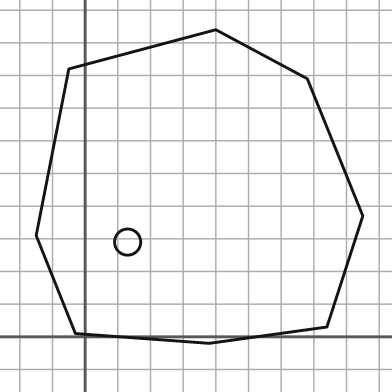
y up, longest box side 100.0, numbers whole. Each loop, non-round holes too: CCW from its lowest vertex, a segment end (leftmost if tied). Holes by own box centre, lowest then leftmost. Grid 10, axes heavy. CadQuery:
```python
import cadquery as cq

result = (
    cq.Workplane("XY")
    .moveTo(38.0, -2.0)
    .lineTo(74.0, 3.0)
    .lineTo(85.0, 37.0)
    .lineTo(68.0, 79.0)
    .lineTo(40.0, 94.0)
    .lineTo(-5.0, 82.0)
    .lineTo(-15.0, 31.0)
    .lineTo(-3.0, 1.0)
    .close()
    .moveTo(13.0, 29.0)
    .circle(4.0)
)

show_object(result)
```